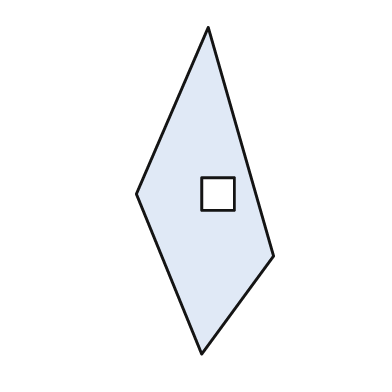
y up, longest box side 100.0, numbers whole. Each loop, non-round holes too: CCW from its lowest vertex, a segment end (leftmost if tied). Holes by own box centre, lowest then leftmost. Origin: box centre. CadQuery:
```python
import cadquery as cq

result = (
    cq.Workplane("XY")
    .moveTo(-1.0, -50.0)
    .lineTo(21.0, -20.0)
    .lineTo(1.0, 50.0)
    .lineTo(-21.0, -1.0)
    .close()
    .moveTo(-1.0, -6.0)
    .lineTo(9.0, -6.0)
    .lineTo(9.0, 4.0)
    .lineTo(-1.0, 4.0)
    .close()
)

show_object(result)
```